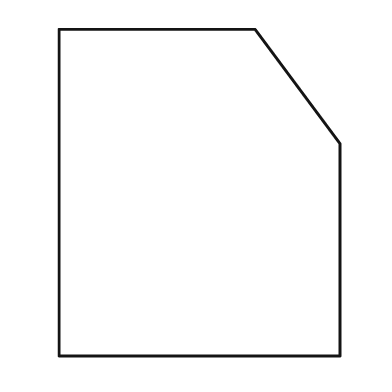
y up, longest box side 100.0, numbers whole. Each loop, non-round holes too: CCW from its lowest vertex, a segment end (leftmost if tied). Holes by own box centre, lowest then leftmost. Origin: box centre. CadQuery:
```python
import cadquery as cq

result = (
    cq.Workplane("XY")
    .moveTo(-43.0, -50.0)
    .lineTo(43.0, -50.0)
    .lineTo(43.0, 15.0)
    .lineTo(17.0, 50.0)
    .lineTo(-43.0, 50.0)
    .close()
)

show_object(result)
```